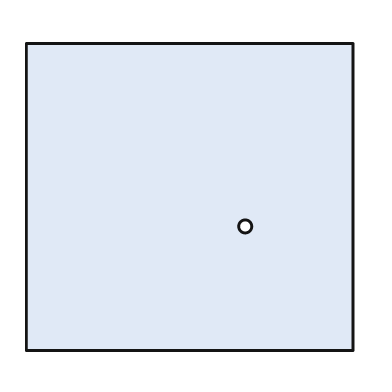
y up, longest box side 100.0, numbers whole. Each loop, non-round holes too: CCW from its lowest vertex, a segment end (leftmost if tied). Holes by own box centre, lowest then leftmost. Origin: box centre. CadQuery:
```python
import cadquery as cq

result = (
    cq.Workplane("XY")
    .moveTo(-50.0, -47.0)
    .lineTo(50.0, -47.0)
    .lineTo(50.0, 47.0)
    .lineTo(-50.0, 47.0)
    .close()
    .moveTo(17.0, -9.0)
    .circle(2.0)
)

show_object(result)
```